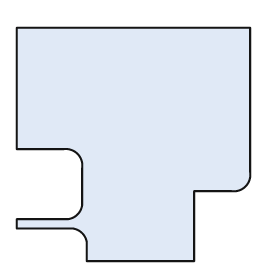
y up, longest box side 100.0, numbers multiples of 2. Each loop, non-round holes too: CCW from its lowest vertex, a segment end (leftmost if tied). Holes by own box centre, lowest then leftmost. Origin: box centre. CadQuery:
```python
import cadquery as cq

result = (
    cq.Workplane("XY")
    .moveTo(-20.0, -50.0)
    .lineTo(26.0, -50.0)
    .lineTo(26.0, -20.0)
    .lineTo(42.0, -20.0)
    .threePointArc((48.0, -18.0), (50.0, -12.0))
    .lineTo(50.0, 50.0)
    .lineTo(-50.0, 50.0)
    .lineTo(-50.0, -2.0)
    .lineTo(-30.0, -2.0)
    .threePointArc((-24.0, -4.0), (-22.0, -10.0))
    .lineTo(-22.0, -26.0)
    .threePointArc((-24.0, -30.0), (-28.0, -32.0))
    .lineTo(-50.0, -32.0)
    .lineTo(-50.0, -36.0)
    .lineTo(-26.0, -36.0)
    .threePointArc((-22.0, -38.0), (-20.0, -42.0))
    .close()
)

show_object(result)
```